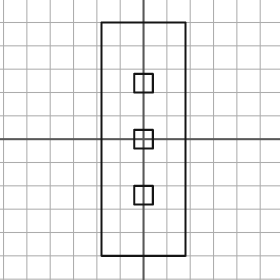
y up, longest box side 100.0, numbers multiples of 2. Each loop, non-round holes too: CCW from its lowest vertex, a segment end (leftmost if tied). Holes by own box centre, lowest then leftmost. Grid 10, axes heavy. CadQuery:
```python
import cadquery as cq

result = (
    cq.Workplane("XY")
    .moveTo(-18.0, -50.0)
    .lineTo(18.0, -50.0)
    .lineTo(18.0, 50.0)
    .lineTo(-18.0, 50.0)
    .close()
    .moveTo(-4.0, -28.0)
    .lineTo(4.0, -28.0)
    .lineTo(4.0, -20.0)
    .lineTo(-4.0, -20.0)
    .close()
    .moveTo(-4.0, -4.0)
    .lineTo(4.0, -4.0)
    .lineTo(4.0, 4.0)
    .lineTo(-4.0, 4.0)
    .close()
    .moveTo(-4.0, 20.0)
    .lineTo(4.0, 20.0)
    .lineTo(4.0, 28.0)
    .lineTo(-4.0, 28.0)
    .close()
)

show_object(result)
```